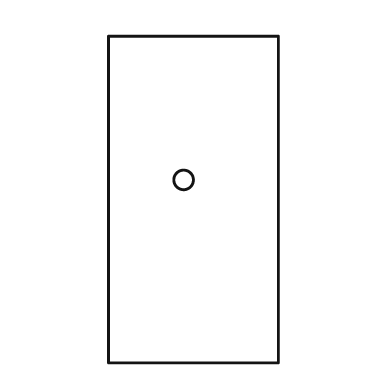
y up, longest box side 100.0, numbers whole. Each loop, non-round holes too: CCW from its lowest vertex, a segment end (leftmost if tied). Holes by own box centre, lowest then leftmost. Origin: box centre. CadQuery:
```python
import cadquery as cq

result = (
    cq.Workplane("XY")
    .moveTo(-26.0, -50.0)
    .lineTo(26.0, -50.0)
    .lineTo(26.0, 50.0)
    .lineTo(-26.0, 50.0)
    .close()
    .moveTo(-3.0, 6.0)
    .circle(3.0)
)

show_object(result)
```